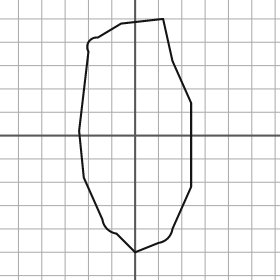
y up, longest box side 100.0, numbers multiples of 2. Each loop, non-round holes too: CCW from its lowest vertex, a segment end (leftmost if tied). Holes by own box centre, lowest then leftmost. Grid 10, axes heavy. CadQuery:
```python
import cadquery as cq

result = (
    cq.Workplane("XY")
    .moveTo(0.0, -50.0)
    .lineTo(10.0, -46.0)
    .threePointArc((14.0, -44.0), (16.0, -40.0))
    .lineTo(24.0, -22.0)
    .lineTo(24.0, 14.0)
    .lineTo(16.0, 32.0)
    .lineTo(12.0, 50.0)
    .lineTo(-6.0, 48.0)
    .lineTo(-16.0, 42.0)
    .threePointArc((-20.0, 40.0), (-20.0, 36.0))
    .lineTo(-24.0, 2.0)
    .lineTo(-22.0, -18.0)
    .lineTo(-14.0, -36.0)
    .threePointArc((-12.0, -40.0), (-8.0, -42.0))
    .close()
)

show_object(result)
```